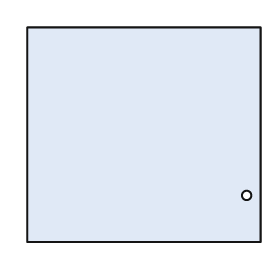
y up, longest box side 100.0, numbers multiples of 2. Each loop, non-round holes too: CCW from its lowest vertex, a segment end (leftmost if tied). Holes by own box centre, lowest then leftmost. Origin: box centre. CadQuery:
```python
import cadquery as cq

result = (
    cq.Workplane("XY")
    .moveTo(-50.0, -46.0)
    .lineTo(50.0, -46.0)
    .lineTo(50.0, 46.0)
    .lineTo(-50.0, 46.0)
    .close()
    .moveTo(44.0, -26.0)
    .circle(2.0)
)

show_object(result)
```